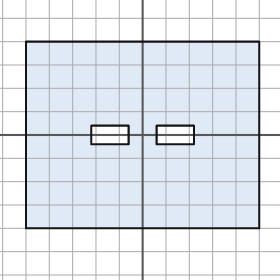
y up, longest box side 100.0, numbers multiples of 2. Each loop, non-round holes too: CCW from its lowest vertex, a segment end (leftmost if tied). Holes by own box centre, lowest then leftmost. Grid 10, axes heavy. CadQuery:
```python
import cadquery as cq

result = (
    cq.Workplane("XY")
    .moveTo(-50.0, -40.0)
    .lineTo(50.0, -40.0)
    .lineTo(50.0, 40.0)
    .lineTo(-50.0, 40.0)
    .close()
    .moveTo(-22.0, -4.0)
    .lineTo(-6.0, -4.0)
    .lineTo(-6.0, 4.0)
    .lineTo(-22.0, 4.0)
    .close()
    .moveTo(6.0, -4.0)
    .lineTo(22.0, -4.0)
    .lineTo(22.0, 4.0)
    .lineTo(6.0, 4.0)
    .close()
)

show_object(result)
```